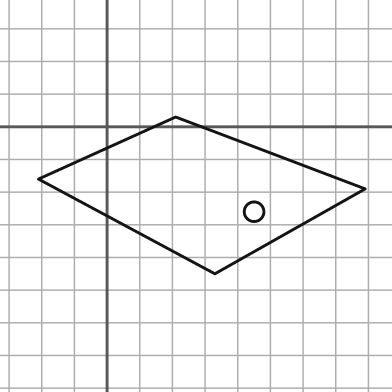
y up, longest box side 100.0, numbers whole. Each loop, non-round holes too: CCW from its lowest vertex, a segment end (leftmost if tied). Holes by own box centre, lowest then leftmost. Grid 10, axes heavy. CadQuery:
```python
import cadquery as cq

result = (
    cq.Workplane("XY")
    .moveTo(33.0, -45.0)
    .lineTo(79.0, -19.0)
    .lineTo(21.0, 3.0)
    .lineTo(-21.0, -16.0)
    .close()
    .moveTo(45.0, -26.0)
    .circle(3.0)
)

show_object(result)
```